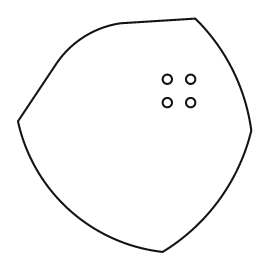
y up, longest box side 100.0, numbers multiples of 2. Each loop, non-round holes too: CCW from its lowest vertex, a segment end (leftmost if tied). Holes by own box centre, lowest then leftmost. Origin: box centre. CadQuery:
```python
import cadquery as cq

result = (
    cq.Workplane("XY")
    .moveTo(12.0, -50.0)
    .threePointArc((36.0, -28.0), (50.0, 2.0))
    .threePointArc((42.0, 28.0), (26.0, 50.0))
    .lineTo(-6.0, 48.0)
    .threePointArc((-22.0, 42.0), (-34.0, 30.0))
    .lineTo(-50.0, 6.0)
    .threePointArc((-28.0, -32.0), (12.0, -50.0))
    .close()
    .moveTo(14.0, 14.0)
    .circle(2.0)
    .moveTo(24.0, 14.0)
    .circle(2.0)
    .moveTo(14.0, 24.0)
    .circle(2.0)
    .moveTo(24.0, 24.0)
    .circle(2.0)
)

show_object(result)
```